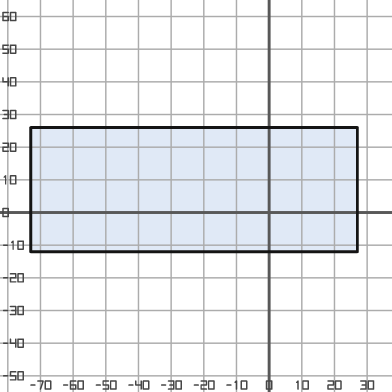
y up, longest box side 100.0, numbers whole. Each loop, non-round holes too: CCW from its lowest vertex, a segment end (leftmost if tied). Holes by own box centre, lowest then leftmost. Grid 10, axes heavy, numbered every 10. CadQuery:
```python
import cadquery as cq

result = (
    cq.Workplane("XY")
    .moveTo(-73.0, -12.0)
    .lineTo(27.0, -12.0)
    .lineTo(27.0, 26.0)
    .lineTo(-73.0, 26.0)
    .close()
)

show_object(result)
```